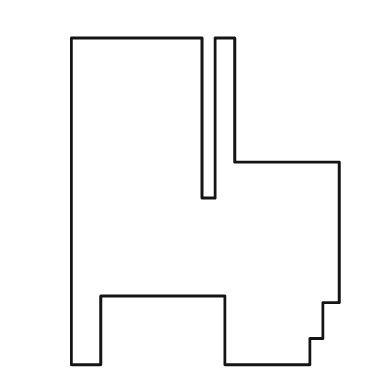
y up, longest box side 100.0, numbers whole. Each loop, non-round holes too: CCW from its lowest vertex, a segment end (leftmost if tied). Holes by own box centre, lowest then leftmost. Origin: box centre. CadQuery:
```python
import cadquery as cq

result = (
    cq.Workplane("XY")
    .moveTo(-41.0, -50.0)
    .lineTo(-32.0, -50.0)
    .lineTo(-32.0, -29.0)
    .lineTo(6.0, -29.0)
    .lineTo(6.0, -50.0)
    .lineTo(32.0, -50.0)
    .lineTo(32.0, -42.0)
    .lineTo(36.0, -42.0)
    .lineTo(36.0, -31.0)
    .lineTo(41.0, -31.0)
    .lineTo(41.0, 12.0)
    .lineTo(9.0, 12.0)
    .lineTo(9.0, 50.0)
    .lineTo(3.0, 50.0)
    .lineTo(3.0, 1.0)
    .lineTo(-1.0, 1.0)
    .lineTo(-1.0, 50.0)
    .lineTo(-41.0, 50.0)
    .close()
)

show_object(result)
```